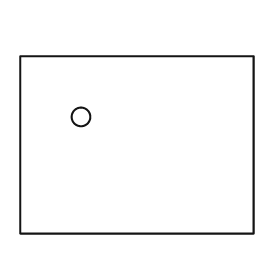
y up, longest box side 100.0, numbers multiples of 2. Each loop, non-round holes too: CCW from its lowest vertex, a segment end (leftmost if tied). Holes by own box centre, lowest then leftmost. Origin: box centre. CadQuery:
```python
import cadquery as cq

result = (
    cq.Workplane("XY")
    .moveTo(-50.0, -38.0)
    .lineTo(50.0, -38.0)
    .lineTo(50.0, 38.0)
    .lineTo(-50.0, 38.0)
    .close()
    .moveTo(-24.0, 12.0)
    .circle(4.0)
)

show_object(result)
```